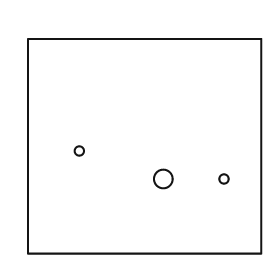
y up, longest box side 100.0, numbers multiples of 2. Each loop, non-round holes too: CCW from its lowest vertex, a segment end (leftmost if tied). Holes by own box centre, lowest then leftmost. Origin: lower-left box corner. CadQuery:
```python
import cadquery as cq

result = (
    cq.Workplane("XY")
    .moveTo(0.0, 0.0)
    .lineTo(100.0, 0.0)
    .lineTo(100.0, 92.0)
    .lineTo(0.0, 92.0)
    .close()
    .moveTo(58.0, 32.0)
    .circle(4.0)
    .moveTo(84.0, 32.0)
    .circle(2.0)
    .moveTo(22.0, 44.0)
    .circle(2.0)
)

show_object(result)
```